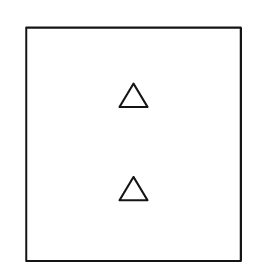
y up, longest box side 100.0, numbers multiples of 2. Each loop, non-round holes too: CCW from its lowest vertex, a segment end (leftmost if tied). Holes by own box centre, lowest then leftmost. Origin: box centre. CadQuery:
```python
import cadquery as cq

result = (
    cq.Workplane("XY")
    .moveTo(-46.0, -50.0)
    .lineTo(46.0, -50.0)
    .lineTo(46.0, 50.0)
    .lineTo(-46.0, 50.0)
    .close()
    .moveTo(-6.0, -24.0)
    .lineTo(6.0, -24.0)
    .lineTo(0.0, -14.0)
    .close()
    .moveTo(-6.0, 16.0)
    .lineTo(6.0, 16.0)
    .lineTo(0.0, 26.0)
    .close()
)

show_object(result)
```